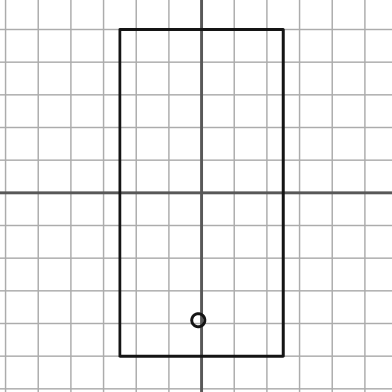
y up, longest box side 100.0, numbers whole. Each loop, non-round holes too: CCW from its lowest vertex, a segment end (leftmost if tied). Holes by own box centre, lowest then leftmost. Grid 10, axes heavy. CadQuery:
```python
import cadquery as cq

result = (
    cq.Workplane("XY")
    .moveTo(-25.0, -50.0)
    .lineTo(25.0, -50.0)
    .lineTo(25.0, 50.0)
    .lineTo(-25.0, 50.0)
    .close()
    .moveTo(-1.0, -39.0)
    .circle(2.0)
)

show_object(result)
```